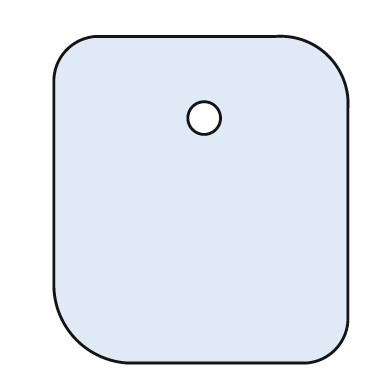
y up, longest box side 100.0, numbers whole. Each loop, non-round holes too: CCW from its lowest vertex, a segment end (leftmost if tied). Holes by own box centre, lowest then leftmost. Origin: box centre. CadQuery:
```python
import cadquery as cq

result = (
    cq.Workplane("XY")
    .moveTo(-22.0, -50.0)
    .lineTo(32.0, -50.0)
    .threePointArc((41.0, -46.0), (45.0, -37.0))
    .lineTo(45.0, 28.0)
    .threePointArc((39.0, 44.0), (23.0, 50.0))
    .lineTo(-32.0, 50.0)
    .threePointArc((-41.0, 46.0), (-45.0, 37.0))
    .lineTo(-45.0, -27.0)
    .threePointArc((-38.0, -43.0), (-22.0, -50.0))
    .close()
    .moveTo(1.0, 25.0)
    .circle(5.0)
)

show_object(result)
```